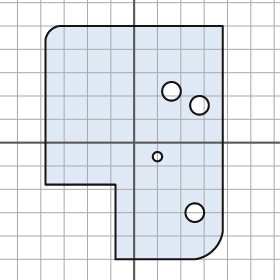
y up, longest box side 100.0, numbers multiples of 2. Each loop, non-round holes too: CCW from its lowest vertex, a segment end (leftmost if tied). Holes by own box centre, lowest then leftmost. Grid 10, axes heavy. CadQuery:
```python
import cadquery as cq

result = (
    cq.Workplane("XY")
    .moveTo(-8.0, -50.0)
    .lineTo(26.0, -50.0)
    .threePointArc((34.0, -46.0), (38.0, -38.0))
    .lineTo(38.0, 50.0)
    .lineTo(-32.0, 50.0)
    .threePointArc((-36.0, 48.0), (-38.0, 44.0))
    .lineTo(-38.0, -18.0)
    .lineTo(-8.0, -18.0)
    .close()
    .moveTo(26.0, -30.0)
    .circle(4.0)
    .moveTo(10.0, -6.0)
    .circle(2.0)
    .moveTo(28.0, 16.0)
    .circle(4.0)
    .moveTo(16.0, 22.0)
    .circle(4.0)
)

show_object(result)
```